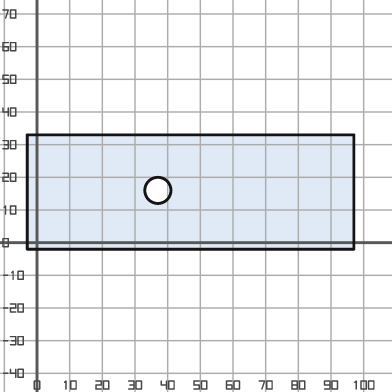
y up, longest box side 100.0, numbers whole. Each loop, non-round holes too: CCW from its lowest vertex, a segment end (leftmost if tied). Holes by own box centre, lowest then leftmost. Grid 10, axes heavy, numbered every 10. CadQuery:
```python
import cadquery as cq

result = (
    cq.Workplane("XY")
    .moveTo(-3.0, -2.0)
    .lineTo(97.0, -2.0)
    .lineTo(97.0, 33.0)
    .lineTo(-3.0, 33.0)
    .close()
    .moveTo(37.0, 16.0)
    .circle(4.0)
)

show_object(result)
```